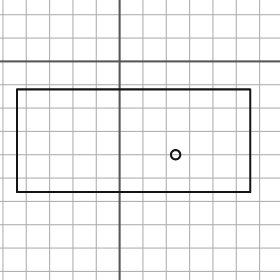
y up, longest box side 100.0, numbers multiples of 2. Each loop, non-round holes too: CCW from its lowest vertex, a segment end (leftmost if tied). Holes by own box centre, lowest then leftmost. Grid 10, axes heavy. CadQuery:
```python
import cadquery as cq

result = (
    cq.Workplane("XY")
    .moveTo(-44.0, -56.0)
    .lineTo(56.0, -56.0)
    .lineTo(56.0, -12.0)
    .lineTo(-44.0, -12.0)
    .close()
    .moveTo(24.0, -40.0)
    .circle(2.0)
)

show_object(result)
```